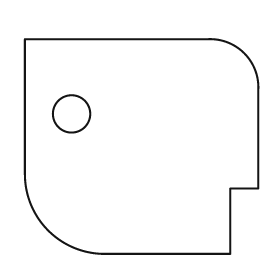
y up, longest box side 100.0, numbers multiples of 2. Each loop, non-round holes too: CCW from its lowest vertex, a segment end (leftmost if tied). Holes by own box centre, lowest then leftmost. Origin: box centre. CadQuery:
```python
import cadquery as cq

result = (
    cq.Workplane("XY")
    .moveTo(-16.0, -46.0)
    .lineTo(38.0, -46.0)
    .lineTo(38.0, -18.0)
    .lineTo(50.0, -18.0)
    .lineTo(50.0, 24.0)
    .threePointArc((44.0, 40.0), (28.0, 46.0))
    .lineTo(-50.0, 46.0)
    .lineTo(-50.0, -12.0)
    .threePointArc((-40.0, -36.0), (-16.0, -46.0))
    .close()
    .moveTo(-30.0, 14.0)
    .circle(8.0)
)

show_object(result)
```